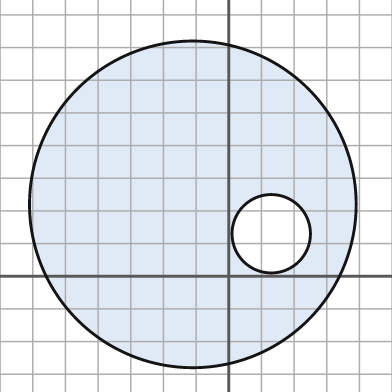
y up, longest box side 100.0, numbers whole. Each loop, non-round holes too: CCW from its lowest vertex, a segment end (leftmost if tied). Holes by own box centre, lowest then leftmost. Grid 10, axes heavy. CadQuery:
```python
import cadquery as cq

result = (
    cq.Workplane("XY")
    .moveTo(-11.0, 22.0)
    .circle(50.0)
    .moveTo(13.0, 13.0)
    .circle(12.0)
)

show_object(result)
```